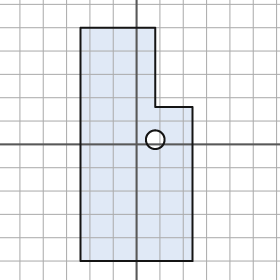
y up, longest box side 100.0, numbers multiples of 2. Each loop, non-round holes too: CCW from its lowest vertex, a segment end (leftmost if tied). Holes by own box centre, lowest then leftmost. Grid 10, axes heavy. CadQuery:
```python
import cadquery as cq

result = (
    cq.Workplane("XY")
    .moveTo(-24.0, -50.0)
    .lineTo(24.0, -50.0)
    .lineTo(24.0, 16.0)
    .lineTo(8.0, 16.0)
    .lineTo(8.0, 50.0)
    .lineTo(-24.0, 50.0)
    .close()
    .moveTo(8.0, 2.0)
    .circle(4.0)
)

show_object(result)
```